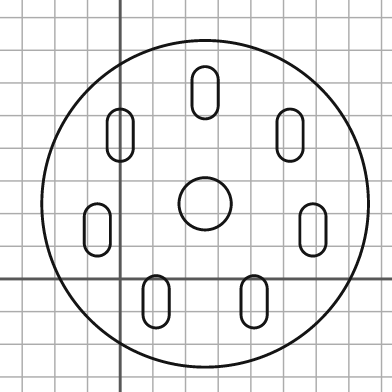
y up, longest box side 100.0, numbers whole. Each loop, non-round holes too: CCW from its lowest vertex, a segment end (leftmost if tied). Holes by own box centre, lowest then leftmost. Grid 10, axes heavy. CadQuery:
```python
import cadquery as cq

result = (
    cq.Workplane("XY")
    .moveTo(26.0, 23.0)
    .circle(50.0)
    .moveTo(7.0, -11.0)
    .threePointArc((11.0, -15.0), (15.0, -11.0))
    .lineTo(15.0, -3.0)
    .threePointArc((11.0, 1.0), (7.0, -3.0))
    .close()
    .moveTo(37.0, -11.0)
    .threePointArc((41.0, -15.0), (45.0, -11.0))
    .lineTo(45.0, -3.0)
    .threePointArc((41.0, 1.0), (37.0, -3.0))
    .close()
    .moveTo(-11.0, 11.0)
    .threePointArc((-7.0, 7.0), (-3.0, 11.0))
    .lineTo(-3.0, 19.0)
    .threePointArc((-7.0, 23.0), (-11.0, 19.0))
    .close()
    .moveTo(55.0, 11.0)
    .threePointArc((59.0, 7.0), (63.0, 11.0))
    .lineTo(63.0, 19.0)
    .threePointArc((59.0, 23.0), (55.0, 19.0))
    .close()
    .moveTo(26.0, 23.0)
    .circle(8.0)
    .moveTo(-4.0, 40.0)
    .threePointArc((0.0, 36.0), (4.0, 40.0))
    .lineTo(4.0, 48.0)
    .threePointArc((0.0, 52.0), (-4.0, 48.0))
    .close()
    .moveTo(48.0, 40.0)
    .threePointArc((52.0, 36.0), (56.0, 40.0))
    .lineTo(56.0, 48.0)
    .threePointArc((52.0, 52.0), (48.0, 48.0))
    .close()
    .moveTo(22.0, 53.0)
    .threePointArc((26.0, 49.0), (30.0, 53.0))
    .lineTo(30.0, 61.0)
    .threePointArc((26.0, 65.0), (22.0, 61.0))
    .close()
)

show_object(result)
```